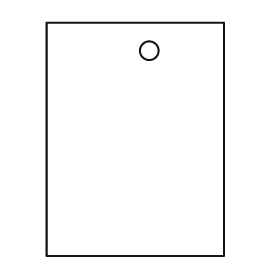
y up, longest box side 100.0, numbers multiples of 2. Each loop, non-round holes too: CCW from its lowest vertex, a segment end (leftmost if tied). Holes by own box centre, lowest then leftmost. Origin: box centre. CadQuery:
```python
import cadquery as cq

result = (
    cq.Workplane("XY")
    .moveTo(-38.0, -50.0)
    .lineTo(38.0, -50.0)
    .lineTo(38.0, 50.0)
    .lineTo(-38.0, 50.0)
    .close()
    .moveTo(6.0, 38.0)
    .circle(4.0)
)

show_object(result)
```